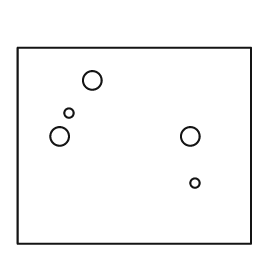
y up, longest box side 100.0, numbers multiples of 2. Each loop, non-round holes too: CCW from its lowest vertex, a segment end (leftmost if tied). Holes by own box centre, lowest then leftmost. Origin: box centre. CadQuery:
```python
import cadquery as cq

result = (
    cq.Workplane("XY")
    .moveTo(-50.0, -42.0)
    .lineTo(50.0, -42.0)
    .lineTo(50.0, 42.0)
    .lineTo(-50.0, 42.0)
    .close()
    .moveTo(26.0, -16.0)
    .circle(2.0)
    .moveTo(-32.0, 4.0)
    .circle(4.0)
    .moveTo(24.0, 4.0)
    .circle(4.0)
    .moveTo(-28.0, 14.0)
    .circle(2.0)
    .moveTo(-18.0, 28.0)
    .circle(4.0)
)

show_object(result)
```